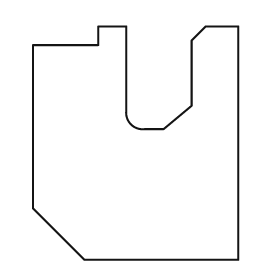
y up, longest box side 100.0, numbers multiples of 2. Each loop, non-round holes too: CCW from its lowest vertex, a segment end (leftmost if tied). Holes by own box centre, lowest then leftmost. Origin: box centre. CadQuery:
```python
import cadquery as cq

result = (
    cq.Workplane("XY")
    .moveTo(-22.0, -50.0)
    .lineTo(44.0, -50.0)
    .lineTo(44.0, 50.0)
    .lineTo(30.0, 50.0)
    .lineTo(24.0, 44.0)
    .lineTo(24.0, 16.0)
    .lineTo(12.0, 6.0)
    .lineTo(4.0, 6.0)
    .threePointArc((-2.0, 8.0), (-4.0, 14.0))
    .lineTo(-4.0, 50.0)
    .lineTo(-16.0, 50.0)
    .lineTo(-16.0, 42.0)
    .lineTo(-44.0, 42.0)
    .lineTo(-44.0, -28.0)
    .close()
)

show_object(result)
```